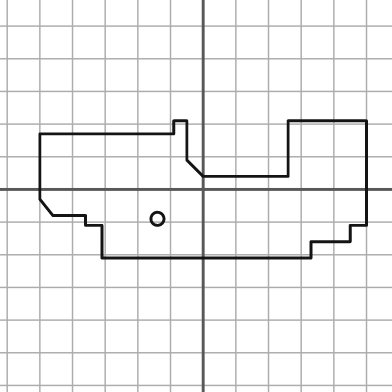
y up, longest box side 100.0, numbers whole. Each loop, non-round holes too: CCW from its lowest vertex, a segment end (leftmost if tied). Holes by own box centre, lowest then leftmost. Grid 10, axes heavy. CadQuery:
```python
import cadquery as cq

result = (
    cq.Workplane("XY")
    .moveTo(-31.0, -21.0)
    .lineTo(33.0, -21.0)
    .lineTo(33.0, -16.0)
    .lineTo(45.0, -16.0)
    .lineTo(45.0, -11.0)
    .lineTo(50.0, -11.0)
    .lineTo(50.0, 21.0)
    .lineTo(26.0, 21.0)
    .lineTo(26.0, 4.0)
    .lineTo(0.0, 4.0)
    .lineTo(-5.0, 9.0)
    .lineTo(-5.0, 21.0)
    .lineTo(-9.0, 21.0)
    .lineTo(-9.0, 17.0)
    .lineTo(-50.0, 17.0)
    .lineTo(-50.0, -3.0)
    .lineTo(-46.0, -8.0)
    .lineTo(-36.0, -8.0)
    .lineTo(-36.0, -11.0)
    .lineTo(-31.0, -11.0)
    .close()
    .moveTo(-14.0, -9.0)
    .circle(2.0)
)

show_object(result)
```